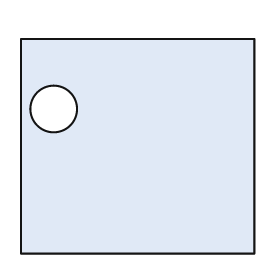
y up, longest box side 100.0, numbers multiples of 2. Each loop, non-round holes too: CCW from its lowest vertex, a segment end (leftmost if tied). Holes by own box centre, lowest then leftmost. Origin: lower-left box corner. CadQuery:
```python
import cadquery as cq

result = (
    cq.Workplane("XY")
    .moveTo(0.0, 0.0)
    .lineTo(100.0, 0.0)
    .lineTo(100.0, 92.0)
    .lineTo(0.0, 92.0)
    .close()
    .moveTo(14.0, 62.0)
    .circle(10.0)
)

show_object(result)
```